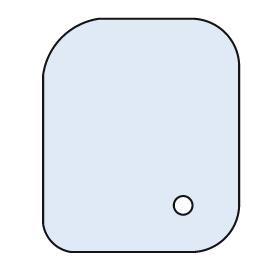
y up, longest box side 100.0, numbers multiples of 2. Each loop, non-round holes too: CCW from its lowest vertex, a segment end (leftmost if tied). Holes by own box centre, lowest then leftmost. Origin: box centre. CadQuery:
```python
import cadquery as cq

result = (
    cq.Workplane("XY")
    .moveTo(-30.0, -50.0)
    .lineTo(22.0, -50.0)
    .threePointArc((36.0, -44.0), (42.0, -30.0))
    .lineTo(42.0, 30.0)
    .threePointArc((36.0, 44.0), (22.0, 50.0))
    .lineTo(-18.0, 50.0)
    .threePointArc((-34.0, 42.0), (-42.0, 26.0))
    .lineTo(-42.0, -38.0)
    .threePointArc((-38.0, -46.0), (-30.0, -50.0))
    .close()
    .moveTo(18.0, -30.0)
    .circle(4.0)
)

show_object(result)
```